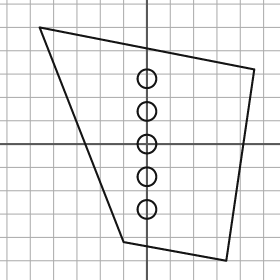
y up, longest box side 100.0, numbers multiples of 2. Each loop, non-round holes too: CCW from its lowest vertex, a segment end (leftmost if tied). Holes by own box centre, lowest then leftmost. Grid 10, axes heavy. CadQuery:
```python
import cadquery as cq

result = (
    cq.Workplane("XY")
    .moveTo(34.0, -50.0)
    .lineTo(46.0, 32.0)
    .lineTo(-46.0, 50.0)
    .lineTo(-10.0, -42.0)
    .close()
    .moveTo(0.0, -28.0)
    .circle(4.0)
    .moveTo(0.0, -14.0)
    .circle(4.0)
    .moveTo(0.0, 0.0)
    .circle(4.0)
    .moveTo(0.0, 14.0)
    .circle(4.0)
    .moveTo(0.0, 28.0)
    .circle(4.0)
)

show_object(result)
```